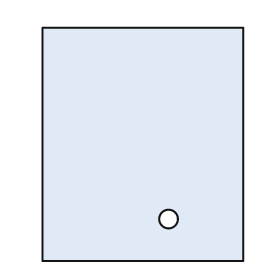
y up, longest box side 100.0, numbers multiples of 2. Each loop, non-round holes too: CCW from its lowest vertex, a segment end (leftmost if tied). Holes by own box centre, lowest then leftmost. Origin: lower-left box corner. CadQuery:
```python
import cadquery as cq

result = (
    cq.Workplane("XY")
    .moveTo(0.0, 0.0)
    .lineTo(86.0, 0.0)
    .lineTo(86.0, 100.0)
    .lineTo(0.0, 100.0)
    .close()
    .moveTo(54.0, 18.0)
    .circle(4.0)
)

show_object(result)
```